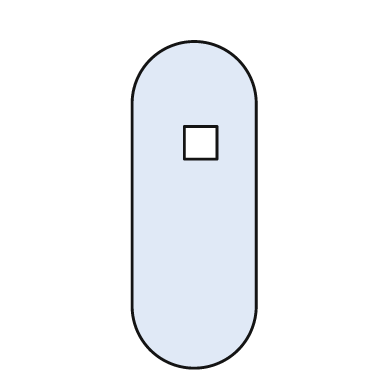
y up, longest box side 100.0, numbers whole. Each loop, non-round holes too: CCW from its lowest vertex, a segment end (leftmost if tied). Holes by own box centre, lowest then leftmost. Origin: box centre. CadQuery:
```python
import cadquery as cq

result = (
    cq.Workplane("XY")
    .moveTo(-19.0, -31.0)
    .threePointArc((0.0, -50.0), (19.0, -31.0))
    .lineTo(19.0, 31.0)
    .threePointArc((0.0, 50.0), (-19.0, 31.0))
    .close()
    .moveTo(-3.0, 14.0)
    .lineTo(7.0, 14.0)
    .lineTo(7.0, 24.0)
    .lineTo(-3.0, 24.0)
    .close()
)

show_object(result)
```